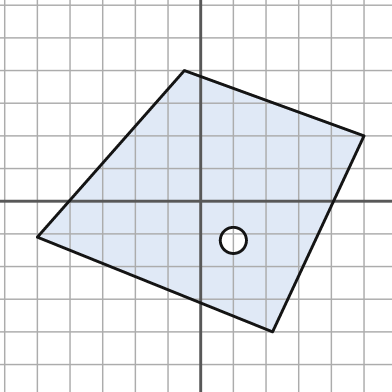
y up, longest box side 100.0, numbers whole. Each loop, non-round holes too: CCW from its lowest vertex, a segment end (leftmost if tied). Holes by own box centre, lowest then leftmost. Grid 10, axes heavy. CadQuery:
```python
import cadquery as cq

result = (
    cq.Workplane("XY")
    .moveTo(22.0, -40.0)
    .lineTo(50.0, 20.0)
    .lineTo(-5.0, 40.0)
    .lineTo(-50.0, -11.0)
    .close()
    .moveTo(10.0, -12.0)
    .circle(4.0)
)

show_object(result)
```